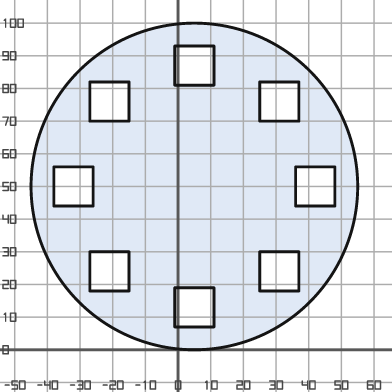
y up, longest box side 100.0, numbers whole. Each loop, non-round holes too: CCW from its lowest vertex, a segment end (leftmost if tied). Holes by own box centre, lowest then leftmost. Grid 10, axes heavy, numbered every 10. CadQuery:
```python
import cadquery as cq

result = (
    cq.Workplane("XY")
    .moveTo(5.0, 50.0)
    .circle(50.0)
    .moveTo(-1.0, 7.0)
    .lineTo(11.0, 7.0)
    .lineTo(11.0, 19.0)
    .lineTo(-1.0, 19.0)
    .close()
    .moveTo(-27.0, 18.0)
    .lineTo(-15.0, 18.0)
    .lineTo(-15.0, 30.0)
    .lineTo(-27.0, 30.0)
    .close()
    .moveTo(25.0, 18.0)
    .lineTo(37.0, 18.0)
    .lineTo(37.0, 30.0)
    .lineTo(25.0, 30.0)
    .close()
    .moveTo(-38.0, 44.0)
    .lineTo(-26.0, 44.0)
    .lineTo(-26.0, 56.0)
    .lineTo(-38.0, 56.0)
    .close()
    .moveTo(36.0, 44.0)
    .lineTo(48.0, 44.0)
    .lineTo(48.0, 56.0)
    .lineTo(36.0, 56.0)
    .close()
    .moveTo(-27.0, 70.0)
    .lineTo(-15.0, 70.0)
    .lineTo(-15.0, 82.0)
    .lineTo(-27.0, 82.0)
    .close()
    .moveTo(25.0, 70.0)
    .lineTo(37.0, 70.0)
    .lineTo(37.0, 82.0)
    .lineTo(25.0, 82.0)
    .close()
    .moveTo(-1.0, 81.0)
    .lineTo(11.0, 81.0)
    .lineTo(11.0, 93.0)
    .lineTo(-1.0, 93.0)
    .close()
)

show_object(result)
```